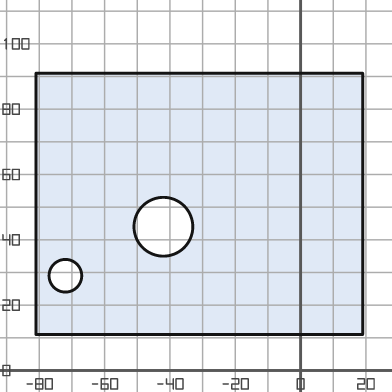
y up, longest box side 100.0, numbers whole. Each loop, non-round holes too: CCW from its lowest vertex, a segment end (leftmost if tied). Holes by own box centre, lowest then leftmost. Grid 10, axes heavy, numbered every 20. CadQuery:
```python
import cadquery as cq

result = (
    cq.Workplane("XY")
    .moveTo(-81.0, 11.0)
    .lineTo(19.0, 11.0)
    .lineTo(19.0, 91.0)
    .lineTo(-81.0, 91.0)
    .close()
    .moveTo(-72.0, 29.0)
    .circle(5.0)
    .moveTo(-42.0, 44.0)
    .circle(9.0)
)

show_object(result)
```